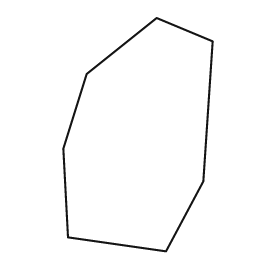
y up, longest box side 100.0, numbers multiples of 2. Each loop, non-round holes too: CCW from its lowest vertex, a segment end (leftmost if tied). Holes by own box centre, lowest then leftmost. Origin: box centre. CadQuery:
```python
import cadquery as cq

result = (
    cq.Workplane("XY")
    .moveTo(12.0, -50.0)
    .lineTo(28.0, -20.0)
    .lineTo(32.0, 40.0)
    .lineTo(8.0, 50.0)
    .lineTo(-22.0, 26.0)
    .lineTo(-32.0, -6.0)
    .lineTo(-30.0, -44.0)
    .close()
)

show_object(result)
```